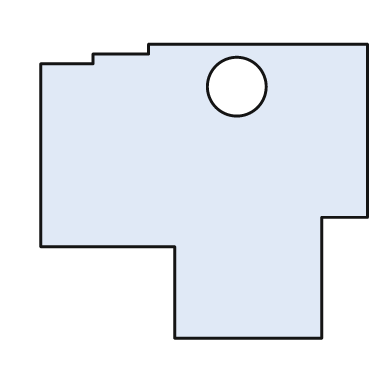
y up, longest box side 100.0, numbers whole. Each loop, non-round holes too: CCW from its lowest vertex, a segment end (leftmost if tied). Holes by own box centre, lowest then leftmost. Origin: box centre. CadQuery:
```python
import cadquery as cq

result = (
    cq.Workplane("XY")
    .moveTo(-9.0, -45.0)
    .lineTo(36.0, -45.0)
    .lineTo(36.0, -8.0)
    .lineTo(50.0, -8.0)
    .lineTo(50.0, 45.0)
    .lineTo(-17.0, 45.0)
    .lineTo(-17.0, 42.0)
    .lineTo(-34.0, 42.0)
    .lineTo(-34.0, 39.0)
    .lineTo(-50.0, 39.0)
    .lineTo(-50.0, -17.0)
    .lineTo(-9.0, -17.0)
    .close()
    .moveTo(10.0, 32.0)
    .circle(9.0)
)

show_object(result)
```